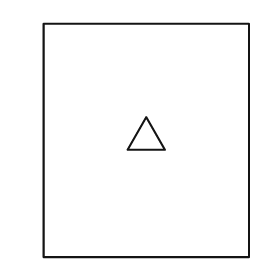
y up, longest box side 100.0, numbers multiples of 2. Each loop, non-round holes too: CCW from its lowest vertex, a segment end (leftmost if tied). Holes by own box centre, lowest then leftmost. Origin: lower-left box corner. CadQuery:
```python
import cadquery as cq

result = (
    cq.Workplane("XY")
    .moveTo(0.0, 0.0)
    .lineTo(88.0, 0.0)
    .lineTo(88.0, 100.0)
    .lineTo(0.0, 100.0)
    .close()
    .moveTo(36.0, 46.0)
    .lineTo(52.0, 46.0)
    .lineTo(44.0, 60.0)
    .close()
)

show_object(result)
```